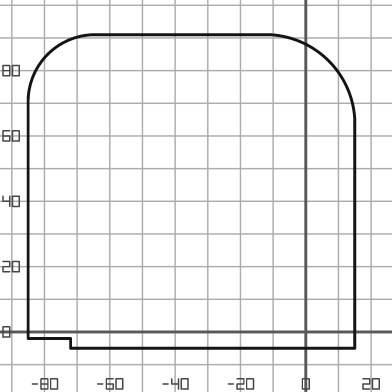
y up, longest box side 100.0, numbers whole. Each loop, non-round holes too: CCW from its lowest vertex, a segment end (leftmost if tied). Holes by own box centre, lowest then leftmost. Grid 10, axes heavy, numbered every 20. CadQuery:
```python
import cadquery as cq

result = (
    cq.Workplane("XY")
    .moveTo(-72.0, -5.0)
    .lineTo(15.0, -5.0)
    .lineTo(15.0, 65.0)
    .threePointArc((7.0, 83.0), (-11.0, 91.0))
    .lineTo(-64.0, 91.0)
    .threePointArc((-79.0, 85.0), (-85.0, 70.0))
    .lineTo(-85.0, -2.0)
    .lineTo(-72.0, -2.0)
    .close()
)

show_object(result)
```